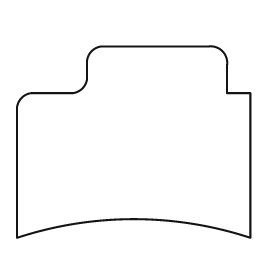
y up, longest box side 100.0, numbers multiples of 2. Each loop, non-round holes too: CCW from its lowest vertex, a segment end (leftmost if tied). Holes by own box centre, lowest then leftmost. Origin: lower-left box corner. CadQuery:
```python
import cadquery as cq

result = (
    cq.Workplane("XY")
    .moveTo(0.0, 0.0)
    .threePointArc((50.0, 8.0), (100.0, 0.0))
    .lineTo(100.0, 62.0)
    .lineTo(90.0, 62.0)
    .lineTo(90.0, 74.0)
    .threePointArc((88.0, 80.0), (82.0, 82.0))
    .lineTo(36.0, 82.0)
    .threePointArc((32.0, 80.0), (30.0, 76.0))
    .lineTo(30.0, 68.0)
    .threePointArc((28.0, 64.0), (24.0, 62.0))
    .lineTo(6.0, 62.0)
    .threePointArc((2.0, 60.0), (0.0, 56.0))
    .close()
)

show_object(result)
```